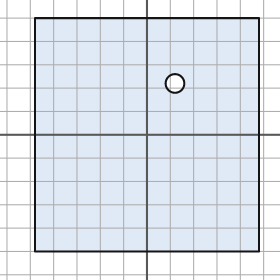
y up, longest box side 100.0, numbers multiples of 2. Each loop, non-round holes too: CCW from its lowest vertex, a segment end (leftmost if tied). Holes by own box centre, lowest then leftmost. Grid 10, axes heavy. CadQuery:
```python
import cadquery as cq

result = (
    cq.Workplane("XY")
    .moveTo(-48.0, -50.0)
    .lineTo(48.0, -50.0)
    .lineTo(48.0, 50.0)
    .lineTo(-48.0, 50.0)
    .close()
    .moveTo(12.0, 22.0)
    .circle(4.0)
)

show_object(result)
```